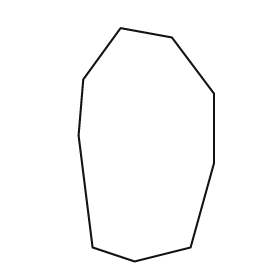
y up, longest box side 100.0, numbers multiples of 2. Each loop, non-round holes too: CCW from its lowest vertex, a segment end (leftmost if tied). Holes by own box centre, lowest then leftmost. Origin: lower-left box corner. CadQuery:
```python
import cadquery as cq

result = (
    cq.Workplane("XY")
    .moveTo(24.0, 0.0)
    .lineTo(48.0, 6.0)
    .lineTo(58.0, 42.0)
    .lineTo(58.0, 72.0)
    .lineTo(40.0, 96.0)
    .lineTo(18.0, 100.0)
    .lineTo(2.0, 78.0)
    .lineTo(0.0, 54.0)
    .lineTo(6.0, 6.0)
    .close()
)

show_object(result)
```